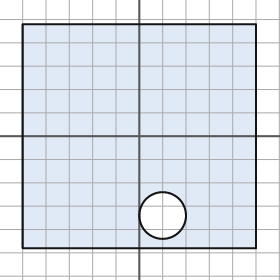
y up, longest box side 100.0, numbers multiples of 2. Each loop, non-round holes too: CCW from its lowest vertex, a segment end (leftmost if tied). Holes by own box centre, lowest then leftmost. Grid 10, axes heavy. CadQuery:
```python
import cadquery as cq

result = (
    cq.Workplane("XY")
    .moveTo(-50.0, -48.0)
    .lineTo(50.0, -48.0)
    .lineTo(50.0, 48.0)
    .lineTo(-50.0, 48.0)
    .close()
    .moveTo(10.0, -34.0)
    .circle(10.0)
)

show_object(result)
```